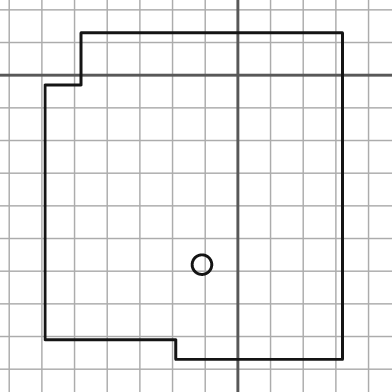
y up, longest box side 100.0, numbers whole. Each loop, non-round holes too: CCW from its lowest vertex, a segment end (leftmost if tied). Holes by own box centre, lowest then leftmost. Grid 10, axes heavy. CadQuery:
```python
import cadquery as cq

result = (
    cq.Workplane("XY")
    .moveTo(-19.0, -87.0)
    .lineTo(32.0, -87.0)
    .lineTo(32.0, 13.0)
    .lineTo(-48.0, 13.0)
    .lineTo(-48.0, -3.0)
    .lineTo(-59.0, -3.0)
    .lineTo(-59.0, -81.0)
    .lineTo(-19.0, -81.0)
    .close()
    .moveTo(-11.0, -58.0)
    .circle(3.0)
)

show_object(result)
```